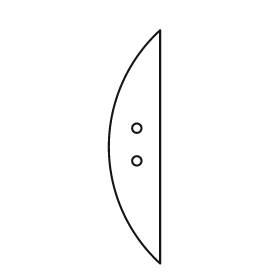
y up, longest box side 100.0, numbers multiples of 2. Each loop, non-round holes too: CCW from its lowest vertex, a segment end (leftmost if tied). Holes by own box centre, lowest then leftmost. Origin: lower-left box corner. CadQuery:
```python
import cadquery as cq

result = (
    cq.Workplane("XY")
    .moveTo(22.0, 0.0)
    .lineTo(22.0, 100.0)
    .threePointArc((0.0, 50.0), (22.0, 0.0))
    .close()
    .moveTo(12.0, 44.0)
    .circle(2.0)
    .moveTo(12.0, 58.0)
    .circle(2.0)
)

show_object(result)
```